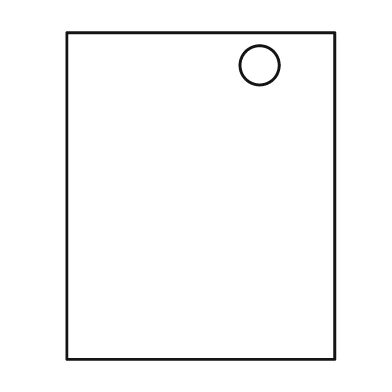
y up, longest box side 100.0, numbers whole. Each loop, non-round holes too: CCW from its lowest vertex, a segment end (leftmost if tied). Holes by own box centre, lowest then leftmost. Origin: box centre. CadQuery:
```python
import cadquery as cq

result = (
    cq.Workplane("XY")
    .moveTo(-41.0, -50.0)
    .lineTo(41.0, -50.0)
    .lineTo(41.0, 50.0)
    .lineTo(-41.0, 50.0)
    .close()
    .moveTo(18.0, 40.0)
    .circle(6.0)
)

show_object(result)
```